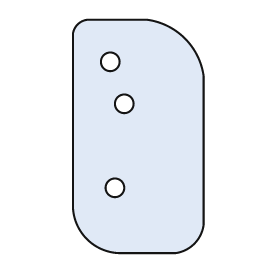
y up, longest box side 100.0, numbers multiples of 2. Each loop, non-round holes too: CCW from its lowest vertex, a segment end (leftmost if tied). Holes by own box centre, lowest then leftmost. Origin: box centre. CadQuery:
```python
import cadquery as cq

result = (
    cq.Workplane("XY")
    .moveTo(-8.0, -50.0)
    .lineTo(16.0, -50.0)
    .threePointArc((24.0, -46.0), (28.0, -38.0))
    .lineTo(28.0, 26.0)
    .threePointArc((20.0, 42.0), (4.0, 50.0))
    .lineTo(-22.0, 50.0)
    .threePointArc((-26.0, 48.0), (-28.0, 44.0))
    .lineTo(-28.0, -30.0)
    .threePointArc((-22.0, -44.0), (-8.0, -50.0))
    .close()
    .moveTo(-10.0, -22.0)
    .circle(4.0)
    .moveTo(-6.0, 14.0)
    .circle(4.0)
    .moveTo(-12.0, 32.0)
    .circle(4.0)
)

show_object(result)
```